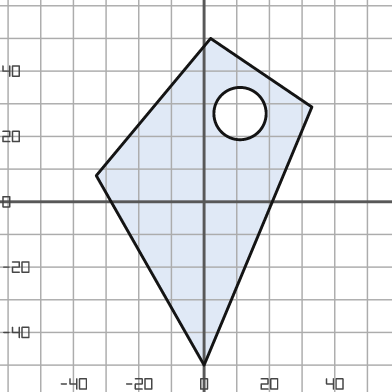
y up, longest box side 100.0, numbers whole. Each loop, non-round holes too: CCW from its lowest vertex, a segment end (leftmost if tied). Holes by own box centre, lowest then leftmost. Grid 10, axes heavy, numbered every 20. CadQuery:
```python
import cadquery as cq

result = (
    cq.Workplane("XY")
    .moveTo(0.0, -50.0)
    .lineTo(33.0, 29.0)
    .lineTo(2.0, 50.0)
    .lineTo(-33.0, 8.0)
    .close()
    .moveTo(11.0, 27.0)
    .circle(8.0)
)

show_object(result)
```